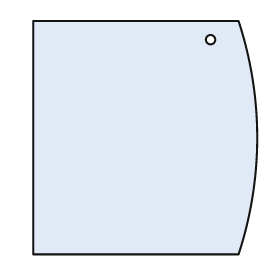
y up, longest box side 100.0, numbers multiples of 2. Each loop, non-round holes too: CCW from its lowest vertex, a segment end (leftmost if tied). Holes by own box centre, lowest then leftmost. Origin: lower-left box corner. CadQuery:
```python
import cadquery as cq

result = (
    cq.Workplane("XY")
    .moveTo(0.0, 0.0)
    .lineTo(88.0, 0.0)
    .threePointArc((96.0, 50.0), (88.0, 100.0))
    .lineTo(0.0, 100.0)
    .close()
    .moveTo(76.0, 92.0)
    .circle(2.0)
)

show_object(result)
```